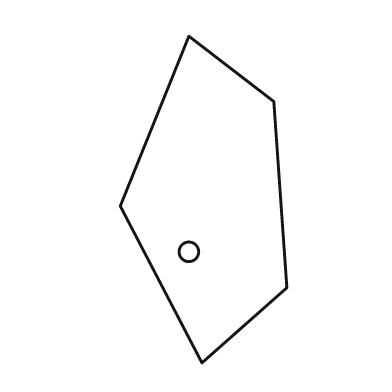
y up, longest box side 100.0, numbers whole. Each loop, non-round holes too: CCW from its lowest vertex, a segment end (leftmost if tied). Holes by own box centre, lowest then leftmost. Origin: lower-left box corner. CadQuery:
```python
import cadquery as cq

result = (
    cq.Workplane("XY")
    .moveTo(25.0, 0.0)
    .lineTo(51.0, 23.0)
    .lineTo(47.0, 80.0)
    .lineTo(21.0, 100.0)
    .lineTo(0.0, 48.0)
    .close()
    .moveTo(21.0, 34.0)
    .circle(3.0)
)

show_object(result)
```